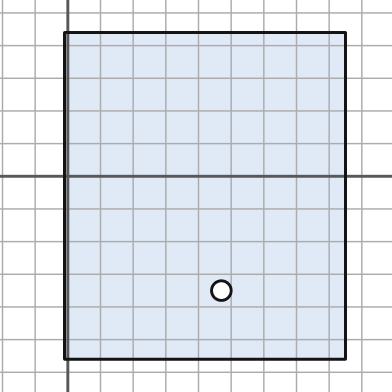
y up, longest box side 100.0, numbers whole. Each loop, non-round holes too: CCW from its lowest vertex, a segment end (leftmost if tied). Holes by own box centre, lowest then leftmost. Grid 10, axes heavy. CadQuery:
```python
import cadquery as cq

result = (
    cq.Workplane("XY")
    .moveTo(-1.0, -56.0)
    .lineTo(85.0, -56.0)
    .lineTo(85.0, 44.0)
    .lineTo(-1.0, 44.0)
    .close()
    .moveTo(47.0, -35.0)
    .circle(3.0)
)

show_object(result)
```